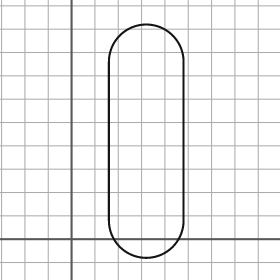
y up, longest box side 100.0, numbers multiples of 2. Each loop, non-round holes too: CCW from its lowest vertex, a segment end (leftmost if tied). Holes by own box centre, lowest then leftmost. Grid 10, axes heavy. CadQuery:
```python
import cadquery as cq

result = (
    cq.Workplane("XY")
    .moveTo(16.0, 8.0)
    .threePointArc((32.0, -8.0), (48.0, 8.0))
    .lineTo(48.0, 76.0)
    .threePointArc((32.0, 92.0), (16.0, 76.0))
    .close()
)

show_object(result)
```